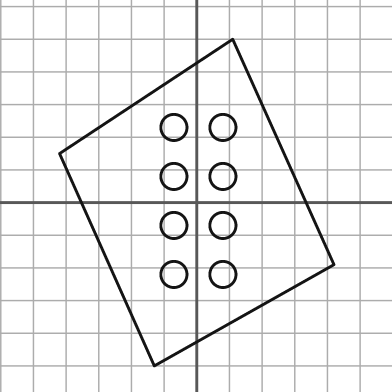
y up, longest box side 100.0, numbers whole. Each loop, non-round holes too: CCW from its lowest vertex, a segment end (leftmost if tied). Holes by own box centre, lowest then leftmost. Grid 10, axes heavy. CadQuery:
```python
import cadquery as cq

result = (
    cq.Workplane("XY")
    .moveTo(-13.0, -50.0)
    .lineTo(42.0, -19.0)
    .lineTo(11.0, 50.0)
    .lineTo(-42.0, 15.0)
    .close()
    .moveTo(-7.0, -22.0)
    .circle(4.0)
    .moveTo(8.0, -22.0)
    .circle(4.0)
    .moveTo(-7.0, -7.0)
    .circle(4.0)
    .moveTo(8.0, -7.0)
    .circle(4.0)
    .moveTo(-7.0, 8.0)
    .circle(4.0)
    .moveTo(8.0, 8.0)
    .circle(4.0)
    .moveTo(-7.0, 23.0)
    .circle(4.0)
    .moveTo(8.0, 23.0)
    .circle(4.0)
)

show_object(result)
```